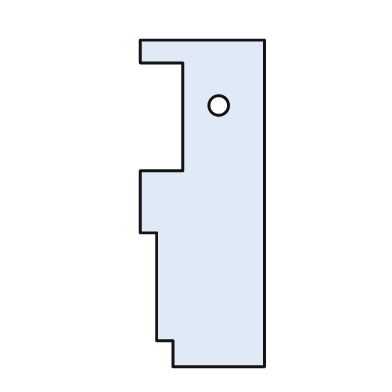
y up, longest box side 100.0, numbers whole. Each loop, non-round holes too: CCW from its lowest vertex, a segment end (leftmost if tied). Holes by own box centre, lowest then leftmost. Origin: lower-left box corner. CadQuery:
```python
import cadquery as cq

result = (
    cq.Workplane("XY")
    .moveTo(10.0, 0.0)
    .lineTo(38.0, 0.0)
    .lineTo(38.0, 100.0)
    .lineTo(0.0, 100.0)
    .lineTo(0.0, 93.0)
    .lineTo(13.0, 93.0)
    .lineTo(13.0, 60.0)
    .lineTo(0.0, 60.0)
    .lineTo(0.0, 41.0)
    .lineTo(5.0, 41.0)
    .lineTo(5.0, 8.0)
    .lineTo(10.0, 8.0)
    .close()
    .moveTo(24.0, 80.0)
    .circle(3.0)
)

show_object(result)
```